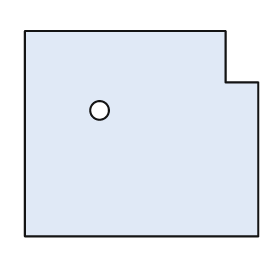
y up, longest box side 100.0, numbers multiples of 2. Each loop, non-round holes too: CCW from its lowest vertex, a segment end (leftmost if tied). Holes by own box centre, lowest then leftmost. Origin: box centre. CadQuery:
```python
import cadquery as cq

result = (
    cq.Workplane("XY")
    .moveTo(-50.0, -44.0)
    .lineTo(50.0, -44.0)
    .lineTo(50.0, 22.0)
    .lineTo(36.0, 22.0)
    .lineTo(36.0, 44.0)
    .lineTo(-50.0, 44.0)
    .close()
    .moveTo(-18.0, 10.0)
    .circle(4.0)
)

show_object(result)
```